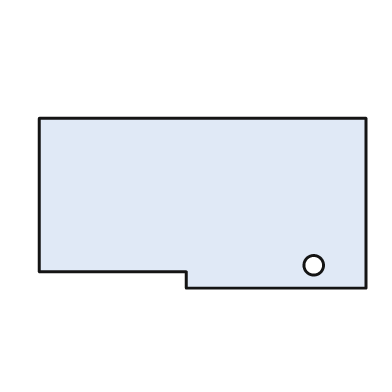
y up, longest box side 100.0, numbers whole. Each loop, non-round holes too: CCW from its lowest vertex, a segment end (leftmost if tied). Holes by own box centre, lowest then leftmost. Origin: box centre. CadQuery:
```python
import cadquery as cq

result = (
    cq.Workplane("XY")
    .moveTo(-5.0, -26.0)
    .lineTo(50.0, -26.0)
    .lineTo(50.0, 26.0)
    .lineTo(-50.0, 26.0)
    .lineTo(-50.0, -21.0)
    .lineTo(-5.0, -21.0)
    .close()
    .moveTo(34.0, -19.0)
    .circle(3.0)
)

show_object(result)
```